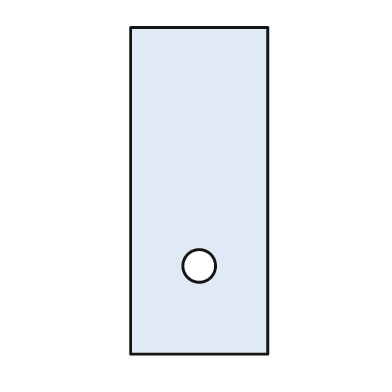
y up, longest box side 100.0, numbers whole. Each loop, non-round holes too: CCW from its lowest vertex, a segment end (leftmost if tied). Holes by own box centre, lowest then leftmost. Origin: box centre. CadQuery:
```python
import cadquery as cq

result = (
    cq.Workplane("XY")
    .moveTo(-21.0, -50.0)
    .lineTo(21.0, -50.0)
    .lineTo(21.0, 50.0)
    .lineTo(-21.0, 50.0)
    .close()
    .moveTo(0.0, -23.0)
    .circle(5.0)
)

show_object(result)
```